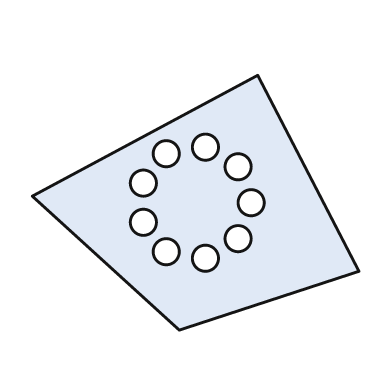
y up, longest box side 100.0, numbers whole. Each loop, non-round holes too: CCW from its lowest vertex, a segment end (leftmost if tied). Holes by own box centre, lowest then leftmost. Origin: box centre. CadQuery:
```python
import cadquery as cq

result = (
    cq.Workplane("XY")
    .moveTo(-5.0, -39.0)
    .lineTo(50.0, -21.0)
    .lineTo(19.0, 39.0)
    .lineTo(-50.0, 2.0)
    .close()
    .moveTo(3.0, -17.0)
    .circle(4.0)
    .moveTo(-9.0, -15.0)
    .circle(4.0)
    .moveTo(13.0, -11.0)
    .circle(4.0)
    .moveTo(-16.0, -6.0)
    .circle(4.0)
    .moveTo(17.0, 0.0)
    .circle(4.0)
    .moveTo(-16.0, 6.0)
    .circle(4.0)
    .moveTo(13.0, 11.0)
    .circle(4.0)
    .moveTo(-9.0, 15.0)
    .circle(4.0)
    .moveTo(3.0, 17.0)
    .circle(4.0)
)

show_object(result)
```